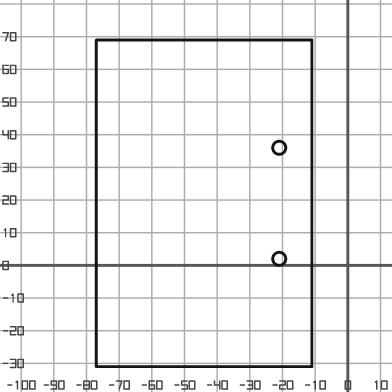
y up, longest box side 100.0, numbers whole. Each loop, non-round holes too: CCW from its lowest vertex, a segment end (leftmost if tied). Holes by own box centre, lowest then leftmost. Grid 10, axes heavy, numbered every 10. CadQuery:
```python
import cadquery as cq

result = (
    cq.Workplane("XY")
    .moveTo(-77.0, -31.0)
    .lineTo(-11.0, -31.0)
    .lineTo(-11.0, 69.0)
    .lineTo(-77.0, 69.0)
    .close()
    .moveTo(-21.0, 2.0)
    .circle(2.0)
    .moveTo(-21.0, 36.0)
    .circle(2.0)
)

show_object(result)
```